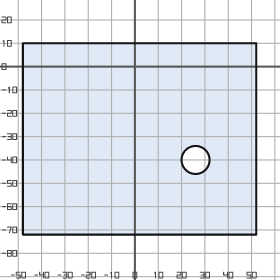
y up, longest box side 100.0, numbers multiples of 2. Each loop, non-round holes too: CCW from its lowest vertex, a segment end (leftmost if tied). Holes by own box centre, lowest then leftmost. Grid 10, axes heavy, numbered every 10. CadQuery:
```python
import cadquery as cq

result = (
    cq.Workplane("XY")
    .moveTo(-48.0, -72.0)
    .lineTo(52.0, -72.0)
    .lineTo(52.0, 10.0)
    .lineTo(-48.0, 10.0)
    .close()
    .moveTo(26.0, -40.0)
    .circle(6.0)
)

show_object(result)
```